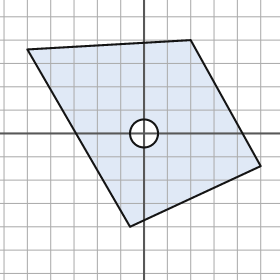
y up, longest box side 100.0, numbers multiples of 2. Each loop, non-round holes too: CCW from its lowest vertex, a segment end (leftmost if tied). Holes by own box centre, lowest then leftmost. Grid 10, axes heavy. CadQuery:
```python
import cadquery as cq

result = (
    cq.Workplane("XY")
    .moveTo(-6.0, -40.0)
    .lineTo(50.0, -14.0)
    .lineTo(20.0, 40.0)
    .lineTo(-50.0, 36.0)
    .close()
    .moveTo(0.0, 0.0)
    .circle(6.0)
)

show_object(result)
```